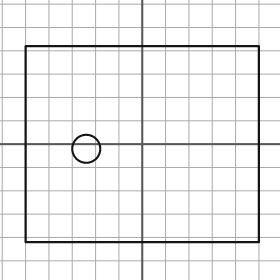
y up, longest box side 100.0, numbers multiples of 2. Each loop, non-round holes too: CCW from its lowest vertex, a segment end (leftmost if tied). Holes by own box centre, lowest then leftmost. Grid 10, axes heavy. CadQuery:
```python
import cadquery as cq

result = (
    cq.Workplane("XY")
    .moveTo(-50.0, -42.0)
    .lineTo(50.0, -42.0)
    .lineTo(50.0, 42.0)
    .lineTo(-50.0, 42.0)
    .close()
    .moveTo(-24.0, -2.0)
    .circle(6.0)
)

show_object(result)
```